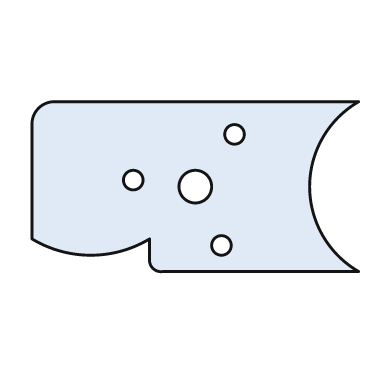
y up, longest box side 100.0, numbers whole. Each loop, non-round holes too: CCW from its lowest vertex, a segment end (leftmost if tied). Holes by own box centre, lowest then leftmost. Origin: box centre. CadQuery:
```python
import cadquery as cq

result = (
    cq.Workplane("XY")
    .moveTo(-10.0, -26.0)
    .lineTo(50.0, -26.0)
    .threePointArc((35.0, 0.0), (50.0, 26.0))
    .lineTo(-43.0, 26.0)
    .threePointArc((-48.0, 24.0), (-50.0, 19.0))
    .lineTo(-50.0, -16.0)
    .threePointArc((-32.0, -21.0), (-14.0, -16.0))
    .lineTo(-14.0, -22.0)
    .threePointArc((-13.0, -25.0), (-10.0, -26.0))
    .close()
    .moveTo(8.0, -18.0)
    .circle(3.0)
    .moveTo(0.0, 0.0)
    .circle(5.0)
    .moveTo(-19.0, 2.0)
    .circle(3.0)
    .moveTo(12.0, 16.0)
    .circle(3.0)
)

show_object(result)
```